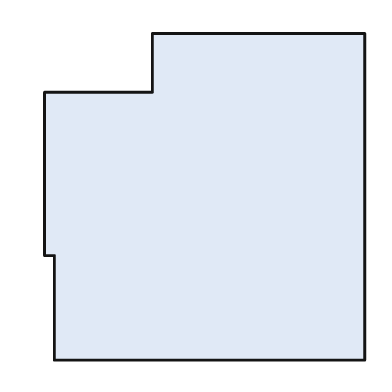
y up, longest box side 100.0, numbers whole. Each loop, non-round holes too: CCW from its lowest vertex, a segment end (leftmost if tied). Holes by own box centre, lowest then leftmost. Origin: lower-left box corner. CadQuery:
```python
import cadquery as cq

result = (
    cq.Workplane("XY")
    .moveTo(3.0, 0.0)
    .lineTo(98.0, 0.0)
    .lineTo(98.0, 100.0)
    .lineTo(33.0, 100.0)
    .lineTo(33.0, 82.0)
    .lineTo(0.0, 82.0)
    .lineTo(0.0, 32.0)
    .lineTo(3.0, 32.0)
    .close()
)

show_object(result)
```